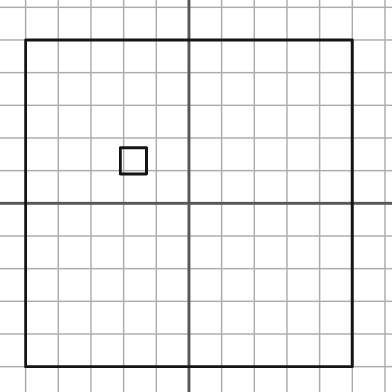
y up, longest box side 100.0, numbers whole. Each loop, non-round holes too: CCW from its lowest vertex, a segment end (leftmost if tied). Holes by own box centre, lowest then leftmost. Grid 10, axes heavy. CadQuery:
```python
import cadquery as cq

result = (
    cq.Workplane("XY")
    .moveTo(-50.0, -50.0)
    .lineTo(50.0, -50.0)
    .lineTo(50.0, 50.0)
    .lineTo(-50.0, 50.0)
    .close()
    .moveTo(-21.0, 9.0)
    .lineTo(-13.0, 9.0)
    .lineTo(-13.0, 17.0)
    .lineTo(-21.0, 17.0)
    .close()
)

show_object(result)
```